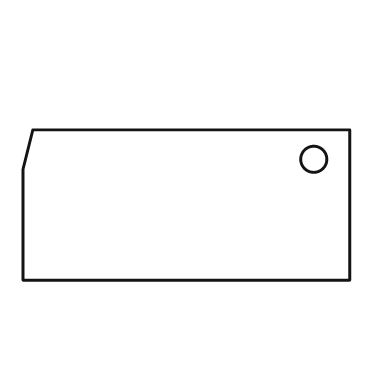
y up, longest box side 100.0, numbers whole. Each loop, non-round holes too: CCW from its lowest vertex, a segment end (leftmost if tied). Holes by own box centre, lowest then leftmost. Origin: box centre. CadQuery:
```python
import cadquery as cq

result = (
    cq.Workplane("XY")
    .moveTo(-50.0, -23.0)
    .lineTo(50.0, -23.0)
    .lineTo(50.0, 23.0)
    .lineTo(-47.0, 23.0)
    .lineTo(-50.0, 11.0)
    .close()
    .moveTo(39.0, 14.0)
    .circle(4.0)
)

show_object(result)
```